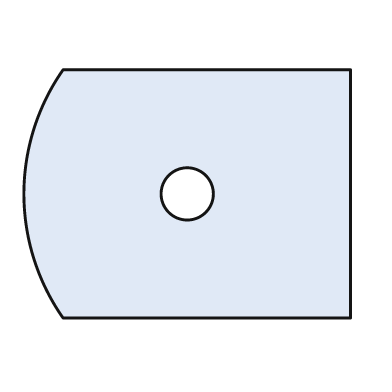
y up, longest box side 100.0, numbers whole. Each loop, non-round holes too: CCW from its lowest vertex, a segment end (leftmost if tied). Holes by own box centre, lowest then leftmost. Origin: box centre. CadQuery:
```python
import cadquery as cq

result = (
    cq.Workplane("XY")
    .moveTo(-38.0, -38.0)
    .lineTo(50.0, -38.0)
    .lineTo(50.0, 38.0)
    .lineTo(-38.0, 38.0)
    .threePointArc((-50.0, 0.0), (-38.0, -38.0))
    .close()
    .moveTo(0.0, 0.0)
    .circle(8.0)
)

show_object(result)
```